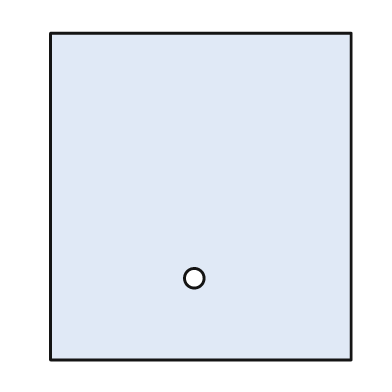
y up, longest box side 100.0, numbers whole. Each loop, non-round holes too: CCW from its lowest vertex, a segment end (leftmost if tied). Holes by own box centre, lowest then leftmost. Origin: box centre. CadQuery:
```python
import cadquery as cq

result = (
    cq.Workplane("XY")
    .moveTo(-46.0, -50.0)
    .lineTo(46.0, -50.0)
    .lineTo(46.0, 50.0)
    .lineTo(-46.0, 50.0)
    .close()
    .moveTo(-2.0, -25.0)
    .circle(3.0)
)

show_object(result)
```